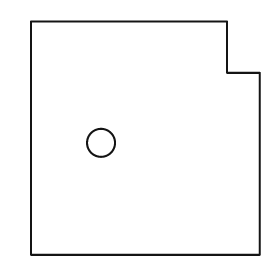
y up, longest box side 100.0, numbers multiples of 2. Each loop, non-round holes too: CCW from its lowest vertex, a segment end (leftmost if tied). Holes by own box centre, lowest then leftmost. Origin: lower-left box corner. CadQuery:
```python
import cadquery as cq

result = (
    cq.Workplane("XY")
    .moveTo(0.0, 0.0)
    .lineTo(98.0, 0.0)
    .lineTo(98.0, 78.0)
    .lineTo(84.0, 78.0)
    .lineTo(84.0, 100.0)
    .lineTo(0.0, 100.0)
    .close()
    .moveTo(30.0, 48.0)
    .circle(6.0)
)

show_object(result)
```